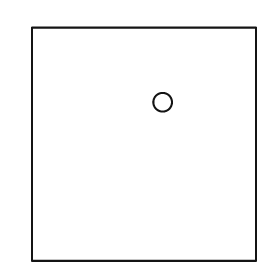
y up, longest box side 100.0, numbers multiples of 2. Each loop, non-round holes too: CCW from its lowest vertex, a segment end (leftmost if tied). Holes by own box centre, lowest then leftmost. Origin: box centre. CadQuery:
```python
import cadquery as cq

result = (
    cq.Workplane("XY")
    .moveTo(-48.0, -50.0)
    .lineTo(48.0, -50.0)
    .lineTo(48.0, 50.0)
    .lineTo(-48.0, 50.0)
    .close()
    .moveTo(8.0, 18.0)
    .circle(4.0)
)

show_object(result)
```